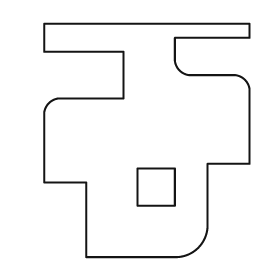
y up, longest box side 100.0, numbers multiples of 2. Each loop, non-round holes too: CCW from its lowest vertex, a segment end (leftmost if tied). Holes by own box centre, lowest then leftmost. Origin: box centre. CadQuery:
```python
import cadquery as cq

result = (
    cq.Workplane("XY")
    .moveTo(-26.0, -50.0)
    .lineTo(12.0, -50.0)
    .threePointArc((22.0, -46.0), (26.0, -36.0))
    .lineTo(26.0, -10.0)
    .lineTo(44.0, -10.0)
    .lineTo(44.0, 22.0)
    .threePointArc((42.0, 26.0), (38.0, 28.0))
    .lineTo(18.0, 28.0)
    .threePointArc((14.0, 30.0), (12.0, 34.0))
    .lineTo(12.0, 44.0)
    .lineTo(44.0, 44.0)
    .lineTo(44.0, 50.0)
    .lineTo(-44.0, 50.0)
    .lineTo(-44.0, 38.0)
    .lineTo(-10.0, 38.0)
    .lineTo(-10.0, 18.0)
    .lineTo(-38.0, 18.0)
    .threePointArc((-42.0, 16.0), (-44.0, 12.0))
    .lineTo(-44.0, -18.0)
    .lineTo(-26.0, -18.0)
    .close()
    .moveTo(-4.0, -28.0)
    .lineTo(12.0, -28.0)
    .lineTo(12.0, -12.0)
    .lineTo(-4.0, -12.0)
    .close()
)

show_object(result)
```